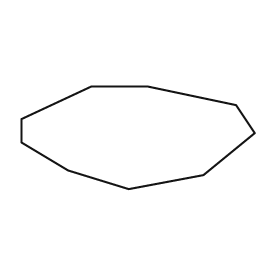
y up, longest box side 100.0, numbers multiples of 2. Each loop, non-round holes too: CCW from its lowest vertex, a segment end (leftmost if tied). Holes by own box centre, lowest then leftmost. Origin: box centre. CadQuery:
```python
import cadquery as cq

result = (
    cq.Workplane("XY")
    .moveTo(-4.0, -22.0)
    .lineTo(28.0, -16.0)
    .lineTo(50.0, 2.0)
    .lineTo(42.0, 14.0)
    .lineTo(4.0, 22.0)
    .lineTo(-20.0, 22.0)
    .lineTo(-50.0, 8.0)
    .lineTo(-50.0, -2.0)
    .lineTo(-30.0, -14.0)
    .close()
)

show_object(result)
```